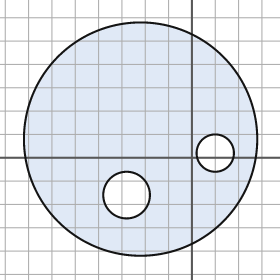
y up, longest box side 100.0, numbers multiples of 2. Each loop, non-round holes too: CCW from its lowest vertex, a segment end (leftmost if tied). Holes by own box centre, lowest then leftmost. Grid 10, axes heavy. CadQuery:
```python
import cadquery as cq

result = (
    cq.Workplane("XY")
    .moveTo(-22.0, 8.0)
    .circle(50.0)
    .moveTo(-28.0, -16.0)
    .circle(10.0)
    .moveTo(10.0, 2.0)
    .circle(8.0)
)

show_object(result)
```